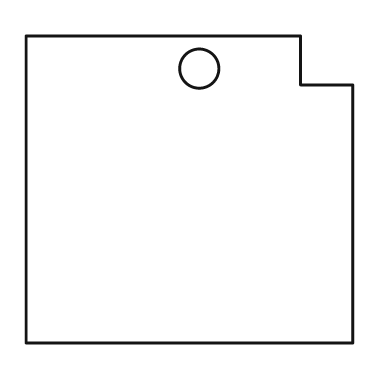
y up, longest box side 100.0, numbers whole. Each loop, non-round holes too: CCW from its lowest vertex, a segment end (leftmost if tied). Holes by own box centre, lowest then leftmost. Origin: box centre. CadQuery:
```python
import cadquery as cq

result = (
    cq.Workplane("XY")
    .moveTo(-50.0, -47.0)
    .lineTo(50.0, -47.0)
    .lineTo(50.0, 32.0)
    .lineTo(34.0, 32.0)
    .lineTo(34.0, 47.0)
    .lineTo(-50.0, 47.0)
    .close()
    .moveTo(3.0, 37.0)
    .circle(6.0)
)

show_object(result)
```